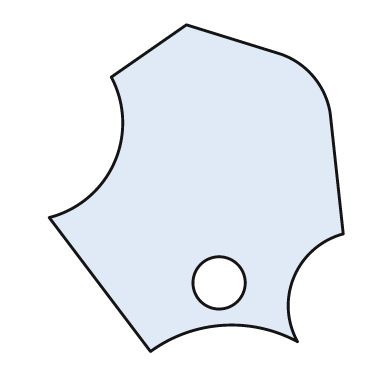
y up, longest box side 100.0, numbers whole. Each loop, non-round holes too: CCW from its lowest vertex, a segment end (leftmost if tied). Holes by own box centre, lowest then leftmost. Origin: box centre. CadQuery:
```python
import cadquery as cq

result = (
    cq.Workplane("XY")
    .moveTo(-14.0, -50.0)
    .threePointArc((8.0, -42.0), (31.0, -47.0))
    .threePointArc((30.0, -27.0), (45.0, -14.0))
    .lineTo(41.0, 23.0)
    .threePointArc((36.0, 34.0), (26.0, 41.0))
    .lineTo(-3.0, 50.0)
    .lineTo(-26.0, 34.0)
    .threePointArc((-25.0, 8.0), (-45.0, -9.0))
    .close()
    .moveTo(7.0, -29.0)
    .circle(8.0)
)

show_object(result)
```